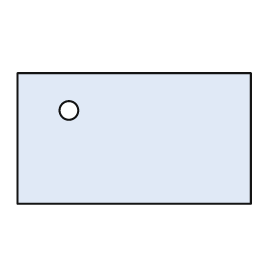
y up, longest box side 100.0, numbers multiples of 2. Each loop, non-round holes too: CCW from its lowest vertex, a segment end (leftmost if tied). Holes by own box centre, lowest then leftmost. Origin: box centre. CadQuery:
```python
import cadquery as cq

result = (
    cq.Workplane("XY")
    .moveTo(-50.0, -28.0)
    .lineTo(50.0, -28.0)
    .lineTo(50.0, 28.0)
    .lineTo(-50.0, 28.0)
    .close()
    .moveTo(-28.0, 12.0)
    .circle(4.0)
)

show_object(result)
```